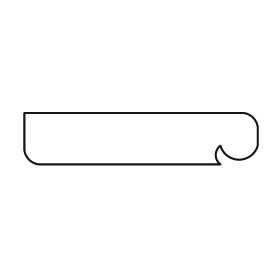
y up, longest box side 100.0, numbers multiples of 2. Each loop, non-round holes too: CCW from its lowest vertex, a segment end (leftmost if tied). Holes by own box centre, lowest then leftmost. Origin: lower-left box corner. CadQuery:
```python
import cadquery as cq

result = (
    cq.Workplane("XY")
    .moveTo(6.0, 0.0)
    .lineTo(84.0, 0.0)
    .threePointArc((82.0, 4.0), (84.0, 8.0))
    .threePointArc((92.0, 2.0), (100.0, 8.0))
    .lineTo(100.0, 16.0)
    .threePointArc((98.0, 20.0), (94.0, 22.0))
    .lineTo(0.0, 22.0)
    .lineTo(0.0, 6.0)
    .threePointArc((2.0, 2.0), (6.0, 0.0))
    .close()
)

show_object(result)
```